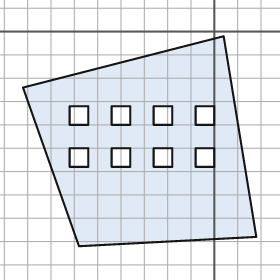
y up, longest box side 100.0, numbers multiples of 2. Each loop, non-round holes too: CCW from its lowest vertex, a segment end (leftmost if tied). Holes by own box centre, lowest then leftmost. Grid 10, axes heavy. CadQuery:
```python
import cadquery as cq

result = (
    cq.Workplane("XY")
    .moveTo(-58.0, -92.0)
    .lineTo(18.0, -88.0)
    .lineTo(4.0, -2.0)
    .lineTo(-82.0, -24.0)
    .close()
    .moveTo(-62.0, -58.0)
    .lineTo(-54.0, -58.0)
    .lineTo(-54.0, -50.0)
    .lineTo(-62.0, -50.0)
    .close()
    .moveTo(-44.0, -58.0)
    .lineTo(-36.0, -58.0)
    .lineTo(-36.0, -50.0)
    .lineTo(-44.0, -50.0)
    .close()
    .moveTo(-26.0, -58.0)
    .lineTo(-18.0, -58.0)
    .lineTo(-18.0, -50.0)
    .lineTo(-26.0, -50.0)
    .close()
    .moveTo(-8.0, -58.0)
    .lineTo(0.0, -58.0)
    .lineTo(0.0, -50.0)
    .lineTo(-8.0, -50.0)
    .close()
    .moveTo(-62.0, -40.0)
    .lineTo(-54.0, -40.0)
    .lineTo(-54.0, -32.0)
    .lineTo(-62.0, -32.0)
    .close()
    .moveTo(-44.0, -40.0)
    .lineTo(-36.0, -40.0)
    .lineTo(-36.0, -32.0)
    .lineTo(-44.0, -32.0)
    .close()
    .moveTo(-26.0, -40.0)
    .lineTo(-18.0, -40.0)
    .lineTo(-18.0, -32.0)
    .lineTo(-26.0, -32.0)
    .close()
    .moveTo(-8.0, -40.0)
    .lineTo(0.0, -40.0)
    .lineTo(0.0, -32.0)
    .lineTo(-8.0, -32.0)
    .close()
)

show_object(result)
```